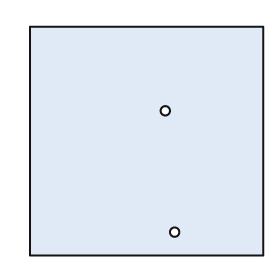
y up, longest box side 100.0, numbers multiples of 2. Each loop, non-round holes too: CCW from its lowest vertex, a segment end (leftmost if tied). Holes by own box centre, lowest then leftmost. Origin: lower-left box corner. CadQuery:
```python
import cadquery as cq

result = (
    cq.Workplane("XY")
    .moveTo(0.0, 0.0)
    .lineTo(100.0, 0.0)
    .lineTo(100.0, 98.0)
    .lineTo(0.0, 98.0)
    .close()
    .moveTo(62.0, 10.0)
    .circle(2.0)
    .moveTo(58.0, 62.0)
    .circle(2.0)
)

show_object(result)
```